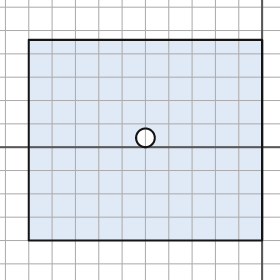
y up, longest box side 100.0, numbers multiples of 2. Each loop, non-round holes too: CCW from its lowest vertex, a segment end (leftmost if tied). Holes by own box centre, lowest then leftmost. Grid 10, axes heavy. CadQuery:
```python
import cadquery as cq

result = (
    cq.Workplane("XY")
    .moveTo(-100.0, -40.0)
    .lineTo(0.0, -40.0)
    .lineTo(0.0, 46.0)
    .lineTo(-100.0, 46.0)
    .close()
    .moveTo(-50.0, 4.0)
    .circle(4.0)
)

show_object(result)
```